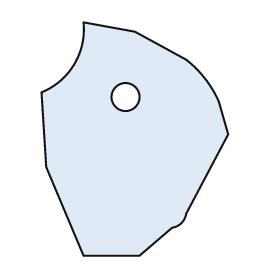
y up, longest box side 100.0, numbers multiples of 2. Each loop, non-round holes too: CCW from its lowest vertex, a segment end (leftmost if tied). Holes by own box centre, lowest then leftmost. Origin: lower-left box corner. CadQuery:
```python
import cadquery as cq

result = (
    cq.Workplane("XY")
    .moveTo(18.0, 0.0)
    .lineTo(42.0, 0.0)
    .lineTo(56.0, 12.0)
    .threePointArc((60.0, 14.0), (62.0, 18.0))
    .lineTo(80.0, 52.0)
    .lineTo(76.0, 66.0)
    .threePointArc((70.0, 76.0), (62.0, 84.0))
    .lineTo(40.0, 96.0)
    .lineTo(18.0, 100.0)
    .threePointArc((14.0, 82.0), (0.0, 70.0))
    .lineTo(2.0, 38.0)
    .close()
    .moveTo(36.0, 68.0)
    .circle(6.0)
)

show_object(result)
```